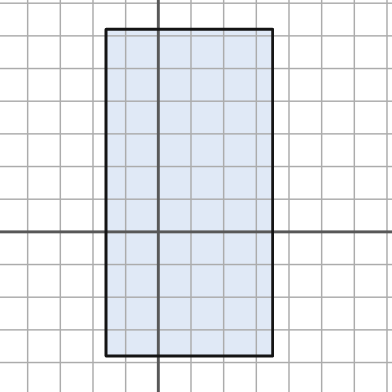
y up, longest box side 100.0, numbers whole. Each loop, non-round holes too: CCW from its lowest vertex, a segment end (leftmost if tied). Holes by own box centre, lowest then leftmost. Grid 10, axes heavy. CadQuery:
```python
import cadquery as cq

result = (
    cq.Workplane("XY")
    .moveTo(-16.0, -38.0)
    .lineTo(35.0, -38.0)
    .lineTo(35.0, 62.0)
    .lineTo(-16.0, 62.0)
    .close()
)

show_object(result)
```